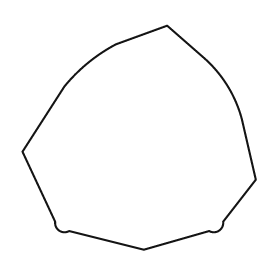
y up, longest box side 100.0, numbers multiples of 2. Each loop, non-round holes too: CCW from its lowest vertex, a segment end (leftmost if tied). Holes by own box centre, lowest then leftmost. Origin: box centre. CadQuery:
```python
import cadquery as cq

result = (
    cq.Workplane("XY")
    .moveTo(2.0, -48.0)
    .lineTo(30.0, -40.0)
    .threePointArc((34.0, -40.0), (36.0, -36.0))
    .lineTo(50.0, -18.0)
    .lineTo(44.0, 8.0)
    .threePointArc((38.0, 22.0), (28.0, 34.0))
    .lineTo(12.0, 48.0)
    .lineTo(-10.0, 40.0)
    .threePointArc((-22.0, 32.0), (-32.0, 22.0))
    .lineTo(-50.0, -6.0)
    .lineTo(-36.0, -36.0)
    .threePointArc((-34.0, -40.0), (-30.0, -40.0))
    .close()
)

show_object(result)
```